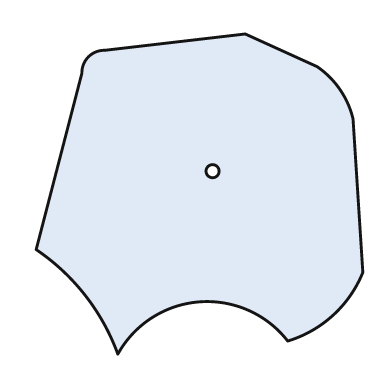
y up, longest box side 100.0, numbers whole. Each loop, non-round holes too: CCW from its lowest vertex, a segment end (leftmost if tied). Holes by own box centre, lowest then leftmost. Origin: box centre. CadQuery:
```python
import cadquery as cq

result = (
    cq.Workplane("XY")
    .moveTo(-25.0, -49.0)
    .threePointArc((0.0, -33.0), (27.0, -45.0))
    .threePointArc((41.0, -37.0), (50.0, -24.0))
    .lineTo(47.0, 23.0)
    .threePointArc((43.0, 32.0), (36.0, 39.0))
    .lineTo(14.0, 49.0)
    .lineTo(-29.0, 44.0)
    .threePointArc((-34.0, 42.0), (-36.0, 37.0))
    .lineTo(-50.0, -17.0)
    .threePointArc((-35.0, -31.0), (-25.0, -49.0))
    .close()
    .moveTo(4.0, 7.0)
    .circle(2.0)
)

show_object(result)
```